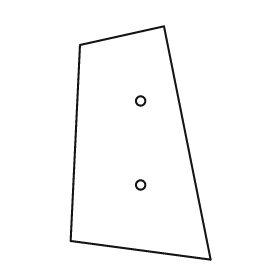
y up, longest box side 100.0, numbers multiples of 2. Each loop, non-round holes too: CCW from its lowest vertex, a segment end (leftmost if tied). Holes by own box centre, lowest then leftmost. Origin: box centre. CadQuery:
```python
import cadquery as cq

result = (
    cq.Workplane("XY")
    .moveTo(30.0, -50.0)
    .lineTo(10.0, 50.0)
    .lineTo(-26.0, 42.0)
    .lineTo(-30.0, -42.0)
    .close()
    .moveTo(0.0, -18.0)
    .circle(2.0)
    .moveTo(0.0, 18.0)
    .circle(2.0)
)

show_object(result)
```